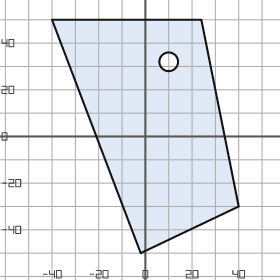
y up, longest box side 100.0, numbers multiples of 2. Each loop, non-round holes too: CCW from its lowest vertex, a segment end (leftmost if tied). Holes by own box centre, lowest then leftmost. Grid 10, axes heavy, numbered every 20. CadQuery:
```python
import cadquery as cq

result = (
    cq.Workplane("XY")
    .moveTo(-2.0, -50.0)
    .lineTo(40.0, -30.0)
    .lineTo(24.0, 50.0)
    .lineTo(-40.0, 50.0)
    .close()
    .moveTo(10.0, 32.0)
    .circle(4.0)
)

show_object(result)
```